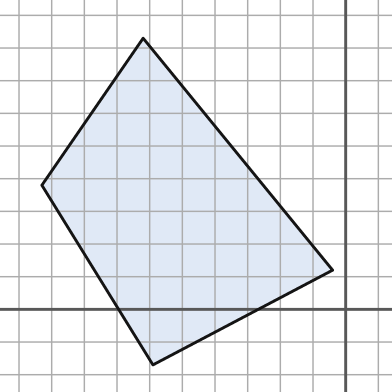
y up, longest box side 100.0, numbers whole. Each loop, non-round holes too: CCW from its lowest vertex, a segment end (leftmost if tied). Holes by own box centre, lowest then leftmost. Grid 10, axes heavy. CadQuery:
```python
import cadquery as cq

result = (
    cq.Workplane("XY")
    .moveTo(-59.0, -17.0)
    .lineTo(-4.0, 12.0)
    .lineTo(-62.0, 83.0)
    .lineTo(-93.0, 38.0)
    .close()
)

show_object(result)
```